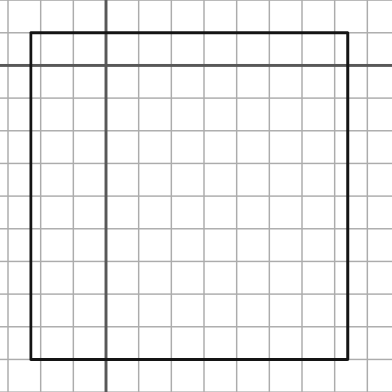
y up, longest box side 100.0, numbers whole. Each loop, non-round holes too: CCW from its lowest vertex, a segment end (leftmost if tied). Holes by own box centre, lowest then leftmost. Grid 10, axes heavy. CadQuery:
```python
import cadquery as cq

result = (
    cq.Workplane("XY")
    .moveTo(-23.0, -90.0)
    .lineTo(74.0, -90.0)
    .lineTo(74.0, 10.0)
    .lineTo(-23.0, 10.0)
    .close()
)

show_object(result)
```